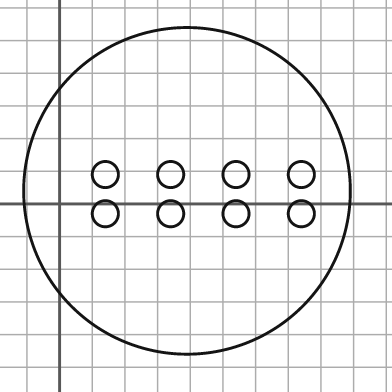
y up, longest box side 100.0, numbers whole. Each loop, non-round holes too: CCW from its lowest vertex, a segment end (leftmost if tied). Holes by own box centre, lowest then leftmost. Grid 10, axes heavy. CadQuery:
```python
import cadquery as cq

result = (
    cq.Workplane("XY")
    .moveTo(39.0, 4.0)
    .circle(50.0)
    .moveTo(14.0, -3.0)
    .circle(4.0)
    .moveTo(34.0, -3.0)
    .circle(4.0)
    .moveTo(54.0, -3.0)
    .circle(4.0)
    .moveTo(74.0, -3.0)
    .circle(4.0)
    .moveTo(14.0, 9.0)
    .circle(4.0)
    .moveTo(34.0, 9.0)
    .circle(4.0)
    .moveTo(54.0, 9.0)
    .circle(4.0)
    .moveTo(74.0, 9.0)
    .circle(4.0)
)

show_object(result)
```